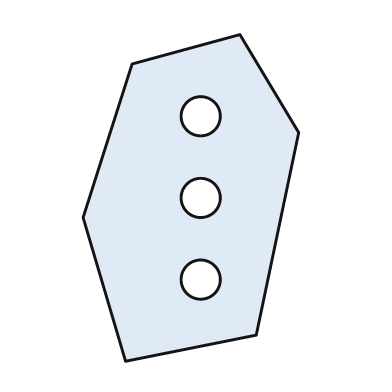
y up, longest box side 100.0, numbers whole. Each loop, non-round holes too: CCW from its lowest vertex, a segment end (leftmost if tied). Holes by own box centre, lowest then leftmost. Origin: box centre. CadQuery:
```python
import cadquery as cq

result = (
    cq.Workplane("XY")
    .moveTo(-20.0, -50.0)
    .lineTo(20.0, -42.0)
    .lineTo(33.0, 20.0)
    .lineTo(15.0, 50.0)
    .lineTo(-18.0, 41.0)
    .lineTo(-33.0, -6.0)
    .close()
    .moveTo(3.0, -25.0)
    .circle(6.0)
    .moveTo(3.0, 0.0)
    .circle(6.0)
    .moveTo(3.0, 25.0)
    .circle(6.0)
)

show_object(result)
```